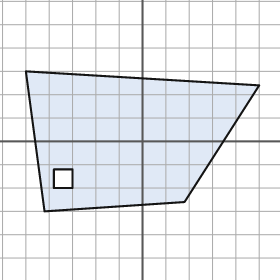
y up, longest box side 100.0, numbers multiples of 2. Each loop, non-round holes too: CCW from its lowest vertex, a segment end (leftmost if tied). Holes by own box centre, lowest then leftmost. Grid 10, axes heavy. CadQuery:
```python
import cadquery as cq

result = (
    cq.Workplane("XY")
    .moveTo(-42.0, -30.0)
    .lineTo(18.0, -26.0)
    .lineTo(50.0, 24.0)
    .lineTo(-50.0, 30.0)
    .close()
    .moveTo(-38.0, -20.0)
    .lineTo(-30.0, -20.0)
    .lineTo(-30.0, -12.0)
    .lineTo(-38.0, -12.0)
    .close()
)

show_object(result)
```